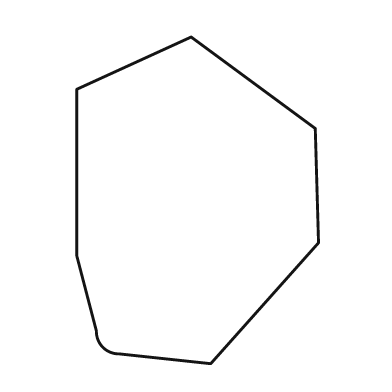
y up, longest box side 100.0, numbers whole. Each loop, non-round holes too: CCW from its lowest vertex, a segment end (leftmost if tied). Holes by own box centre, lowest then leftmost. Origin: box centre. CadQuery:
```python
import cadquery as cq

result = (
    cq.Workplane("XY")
    .moveTo(4.0, -50.0)
    .lineTo(37.0, -13.0)
    .lineTo(36.0, 22.0)
    .lineTo(-2.0, 50.0)
    .lineTo(-37.0, 34.0)
    .lineTo(-37.0, -17.0)
    .lineTo(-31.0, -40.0)
    .threePointArc((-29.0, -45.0), (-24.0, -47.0))
    .close()
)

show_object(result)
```